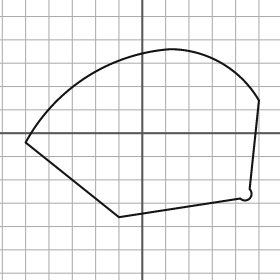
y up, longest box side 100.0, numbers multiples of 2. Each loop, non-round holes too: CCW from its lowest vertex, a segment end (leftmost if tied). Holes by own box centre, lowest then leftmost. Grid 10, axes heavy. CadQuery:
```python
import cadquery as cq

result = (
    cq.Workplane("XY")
    .moveTo(-10.0, -36.0)
    .lineTo(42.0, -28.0)
    .threePointArc((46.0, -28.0), (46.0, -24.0))
    .lineTo(50.0, 14.0)
    .threePointArc((34.0, 30.0), (12.0, 36.0))
    .threePointArc((-24.0, 24.0), (-50.0, -4.0))
    .close()
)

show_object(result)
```